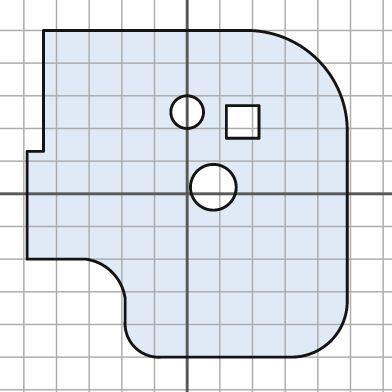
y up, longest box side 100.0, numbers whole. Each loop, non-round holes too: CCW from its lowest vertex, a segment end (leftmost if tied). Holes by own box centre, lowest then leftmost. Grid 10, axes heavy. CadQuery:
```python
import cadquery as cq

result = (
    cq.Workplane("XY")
    .moveTo(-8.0, -50.0)
    .lineTo(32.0, -50.0)
    .threePointArc((44.0, -45.0), (49.0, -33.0))
    .lineTo(49.0, 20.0)
    .threePointArc((40.0, 41.0), (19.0, 50.0))
    .lineTo(-44.0, 50.0)
    .lineTo(-44.0, 13.0)
    .lineTo(-49.0, 13.0)
    .lineTo(-49.0, -20.0)
    .lineTo(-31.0, -20.0)
    .threePointArc((-23.0, -24.0), (-19.0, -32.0))
    .lineTo(-19.0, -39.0)
    .threePointArc((-16.0, -47.0), (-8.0, -50.0))
    .close()
    .moveTo(8.0, 2.0)
    .circle(7.0)
    .moveTo(12.0, 17.0)
    .lineTo(22.0, 17.0)
    .lineTo(22.0, 27.0)
    .lineTo(12.0, 27.0)
    .close()
    .moveTo(0.0, 25.0)
    .circle(5.0)
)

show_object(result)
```